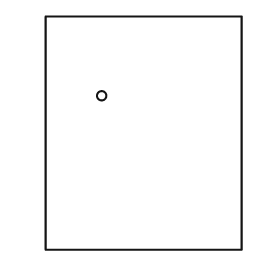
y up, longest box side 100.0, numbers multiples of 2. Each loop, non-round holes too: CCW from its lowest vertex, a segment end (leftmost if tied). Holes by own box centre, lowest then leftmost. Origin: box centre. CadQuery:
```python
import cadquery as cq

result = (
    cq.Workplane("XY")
    .moveTo(-42.0, -50.0)
    .lineTo(42.0, -50.0)
    .lineTo(42.0, 50.0)
    .lineTo(-42.0, 50.0)
    .close()
    .moveTo(-18.0, 16.0)
    .circle(2.0)
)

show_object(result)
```